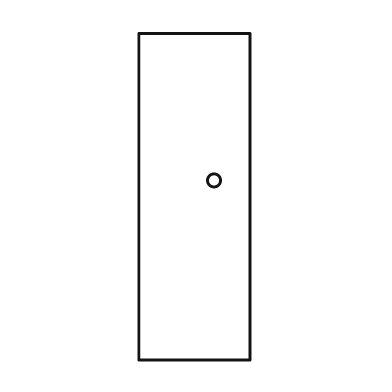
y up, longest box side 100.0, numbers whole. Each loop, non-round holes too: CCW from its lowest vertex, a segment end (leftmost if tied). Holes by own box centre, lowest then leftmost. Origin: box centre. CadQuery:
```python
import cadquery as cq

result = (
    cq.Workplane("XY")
    .moveTo(-17.0, -50.0)
    .lineTo(17.0, -50.0)
    .lineTo(17.0, 50.0)
    .lineTo(-17.0, 50.0)
    .close()
    .moveTo(6.0, 5.0)
    .circle(2.0)
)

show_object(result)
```